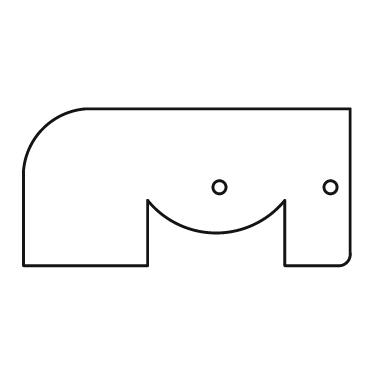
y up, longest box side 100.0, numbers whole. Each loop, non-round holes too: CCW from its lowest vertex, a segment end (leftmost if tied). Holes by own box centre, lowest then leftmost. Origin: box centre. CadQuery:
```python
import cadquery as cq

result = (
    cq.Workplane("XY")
    .moveTo(-50.0, -24.0)
    .lineTo(-12.0, -24.0)
    .lineTo(-12.0, -4.0)
    .threePointArc((9.0, -14.0), (30.0, -4.0))
    .lineTo(30.0, -24.0)
    .lineTo(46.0, -24.0)
    .threePointArc((49.0, -23.0), (50.0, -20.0))
    .lineTo(50.0, 24.0)
    .lineTo(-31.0, 24.0)
    .threePointArc((-44.0, 18.0), (-50.0, 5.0))
    .close()
    .moveTo(10.0, 0.0)
    .circle(2.0)
    .moveTo(44.0, 0.0)
    .circle(2.0)
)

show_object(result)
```